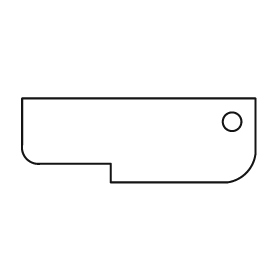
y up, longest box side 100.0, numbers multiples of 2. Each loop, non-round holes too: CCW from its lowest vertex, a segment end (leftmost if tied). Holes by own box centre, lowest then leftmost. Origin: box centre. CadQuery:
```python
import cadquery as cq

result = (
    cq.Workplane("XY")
    .moveTo(-12.0, -18.0)
    .lineTo(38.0, -18.0)
    .threePointArc((46.0, -14.0), (50.0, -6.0))
    .lineTo(50.0, 18.0)
    .lineTo(-50.0, 18.0)
    .lineTo(-50.0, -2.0)
    .threePointArc((-48.0, -8.0), (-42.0, -10.0))
    .lineTo(-12.0, -10.0)
    .close()
    .moveTo(40.0, 8.0)
    .circle(4.0)
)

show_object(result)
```